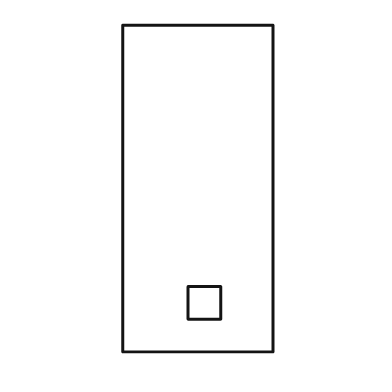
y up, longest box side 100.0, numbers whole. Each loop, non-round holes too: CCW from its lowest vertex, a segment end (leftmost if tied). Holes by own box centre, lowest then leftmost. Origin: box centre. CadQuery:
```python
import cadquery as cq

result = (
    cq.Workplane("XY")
    .moveTo(-23.0, -50.0)
    .lineTo(23.0, -50.0)
    .lineTo(23.0, 50.0)
    .lineTo(-23.0, 50.0)
    .close()
    .moveTo(-3.0, -40.0)
    .lineTo(7.0, -40.0)
    .lineTo(7.0, -30.0)
    .lineTo(-3.0, -30.0)
    .close()
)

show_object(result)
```